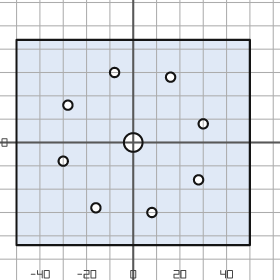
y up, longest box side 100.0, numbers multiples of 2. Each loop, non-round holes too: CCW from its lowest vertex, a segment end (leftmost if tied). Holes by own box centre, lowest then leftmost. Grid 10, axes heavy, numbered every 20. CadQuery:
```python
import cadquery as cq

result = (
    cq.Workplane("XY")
    .moveTo(-50.0, -44.0)
    .lineTo(50.0, -44.0)
    .lineTo(50.0, 44.0)
    .lineTo(-50.0, 44.0)
    .close()
    .moveTo(8.0, -30.0)
    .circle(2.0)
    .moveTo(-16.0, -28.0)
    .circle(2.0)
    .moveTo(28.0, -16.0)
    .circle(2.0)
    .moveTo(-30.0, -8.0)
    .circle(2.0)
    .moveTo(0.0, 0.0)
    .circle(4.0)
    .moveTo(30.0, 8.0)
    .circle(2.0)
    .moveTo(-28.0, 16.0)
    .circle(2.0)
    .moveTo(16.0, 28.0)
    .circle(2.0)
    .moveTo(-8.0, 30.0)
    .circle(2.0)
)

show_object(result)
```